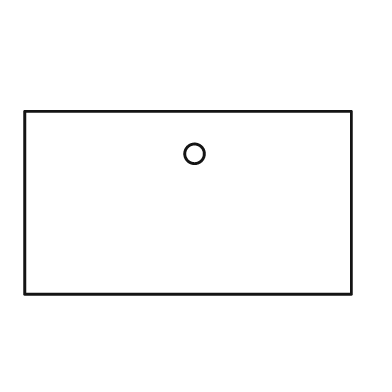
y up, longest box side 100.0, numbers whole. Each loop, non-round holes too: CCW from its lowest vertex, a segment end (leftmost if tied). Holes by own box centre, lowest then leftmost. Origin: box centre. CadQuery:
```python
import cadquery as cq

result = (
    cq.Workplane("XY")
    .moveTo(-50.0, -28.0)
    .lineTo(50.0, -28.0)
    .lineTo(50.0, 28.0)
    .lineTo(-50.0, 28.0)
    .close()
    .moveTo(2.0, 15.0)
    .circle(3.0)
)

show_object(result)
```